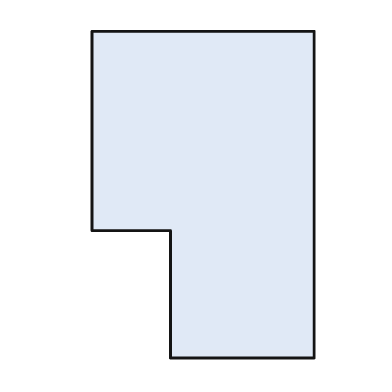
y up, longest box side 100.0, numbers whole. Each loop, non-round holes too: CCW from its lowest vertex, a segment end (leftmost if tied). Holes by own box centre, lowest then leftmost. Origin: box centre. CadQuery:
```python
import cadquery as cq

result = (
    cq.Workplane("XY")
    .moveTo(-10.0, -50.0)
    .lineTo(34.0, -50.0)
    .lineTo(34.0, 50.0)
    .lineTo(-34.0, 50.0)
    .lineTo(-34.0, -11.0)
    .lineTo(-10.0, -11.0)
    .close()
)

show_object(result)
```